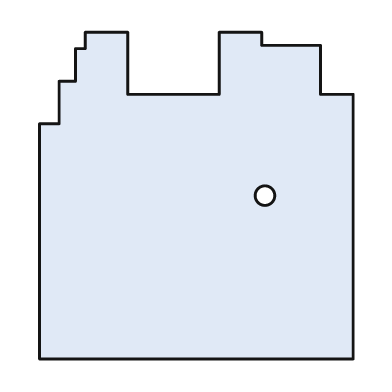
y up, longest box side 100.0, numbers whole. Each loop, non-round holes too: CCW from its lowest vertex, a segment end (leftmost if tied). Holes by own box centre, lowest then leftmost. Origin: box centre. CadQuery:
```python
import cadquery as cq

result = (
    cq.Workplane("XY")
    .moveTo(-48.0, -50.0)
    .lineTo(48.0, -50.0)
    .lineTo(48.0, 31.0)
    .lineTo(38.0, 31.0)
    .lineTo(38.0, 46.0)
    .lineTo(20.0, 46.0)
    .lineTo(20.0, 50.0)
    .lineTo(7.0, 50.0)
    .lineTo(7.0, 31.0)
    .lineTo(-21.0, 31.0)
    .lineTo(-21.0, 50.0)
    .lineTo(-34.0, 50.0)
    .lineTo(-34.0, 45.0)
    .lineTo(-37.0, 45.0)
    .lineTo(-37.0, 35.0)
    .lineTo(-42.0, 35.0)
    .lineTo(-42.0, 22.0)
    .lineTo(-48.0, 22.0)
    .close()
    .moveTo(21.0, 0.0)
    .circle(3.0)
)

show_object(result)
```